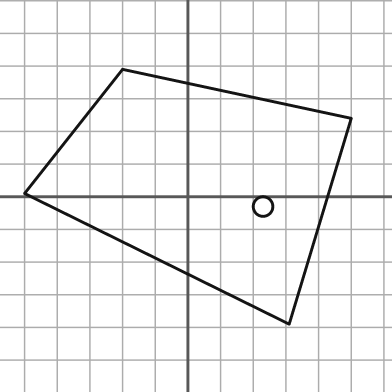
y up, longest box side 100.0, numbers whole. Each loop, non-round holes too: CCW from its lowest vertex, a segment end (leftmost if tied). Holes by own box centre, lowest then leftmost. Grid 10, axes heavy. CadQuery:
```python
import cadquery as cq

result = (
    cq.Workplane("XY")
    .moveTo(31.0, -39.0)
    .lineTo(50.0, 24.0)
    .lineTo(-20.0, 39.0)
    .lineTo(-50.0, 1.0)
    .close()
    .moveTo(23.0, -3.0)
    .circle(3.0)
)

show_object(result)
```